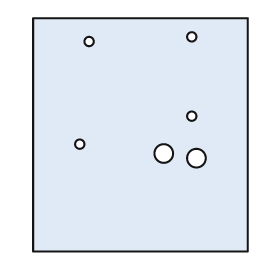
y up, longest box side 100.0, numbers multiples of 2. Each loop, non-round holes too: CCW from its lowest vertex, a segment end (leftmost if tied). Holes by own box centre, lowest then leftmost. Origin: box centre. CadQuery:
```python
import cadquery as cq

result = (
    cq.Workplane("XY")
    .moveTo(-46.0, -50.0)
    .lineTo(46.0, -50.0)
    .lineTo(46.0, 50.0)
    .lineTo(-46.0, 50.0)
    .close()
    .moveTo(24.0, -10.0)
    .circle(4.0)
    .moveTo(10.0, -8.0)
    .circle(4.0)
    .moveTo(-26.0, -4.0)
    .circle(2.0)
    .moveTo(22.0, 8.0)
    .circle(2.0)
    .moveTo(-22.0, 40.0)
    .circle(2.0)
    .moveTo(22.0, 42.0)
    .circle(2.0)
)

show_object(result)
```